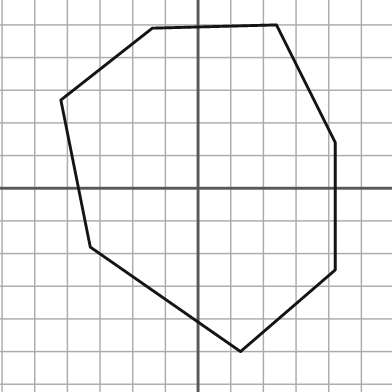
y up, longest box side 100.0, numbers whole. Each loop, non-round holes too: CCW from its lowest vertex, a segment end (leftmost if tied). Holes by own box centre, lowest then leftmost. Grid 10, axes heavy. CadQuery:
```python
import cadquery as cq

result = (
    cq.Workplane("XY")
    .moveTo(13.0, -50.0)
    .lineTo(42.0, -25.0)
    .lineTo(42.0, 14.0)
    .lineTo(24.0, 50.0)
    .lineTo(-14.0, 49.0)
    .lineTo(-42.0, 27.0)
    .lineTo(-33.0, -18.0)
    .close()
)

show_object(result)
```